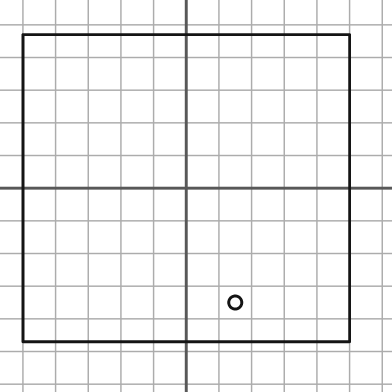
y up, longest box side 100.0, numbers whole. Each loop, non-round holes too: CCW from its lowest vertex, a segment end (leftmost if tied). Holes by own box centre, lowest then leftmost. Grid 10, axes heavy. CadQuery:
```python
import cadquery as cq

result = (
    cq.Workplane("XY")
    .moveTo(-50.0, -47.0)
    .lineTo(50.0, -47.0)
    .lineTo(50.0, 47.0)
    .lineTo(-50.0, 47.0)
    .close()
    .moveTo(15.0, -35.0)
    .circle(2.0)
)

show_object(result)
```